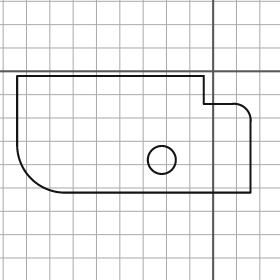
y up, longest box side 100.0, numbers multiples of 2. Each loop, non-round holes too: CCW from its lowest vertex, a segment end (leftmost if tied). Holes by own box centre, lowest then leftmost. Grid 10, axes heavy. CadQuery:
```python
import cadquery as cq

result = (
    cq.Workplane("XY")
    .moveTo(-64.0, -52.0)
    .lineTo(16.0, -52.0)
    .lineTo(16.0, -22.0)
    .threePointArc((14.0, -16.0), (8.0, -14.0))
    .lineTo(-4.0, -14.0)
    .lineTo(-4.0, -2.0)
    .lineTo(-84.0, -2.0)
    .lineTo(-84.0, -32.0)
    .threePointArc((-78.0, -46.0), (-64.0, -52.0))
    .close()
    .moveTo(-22.0, -38.0)
    .circle(6.0)
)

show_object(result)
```